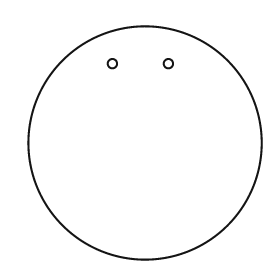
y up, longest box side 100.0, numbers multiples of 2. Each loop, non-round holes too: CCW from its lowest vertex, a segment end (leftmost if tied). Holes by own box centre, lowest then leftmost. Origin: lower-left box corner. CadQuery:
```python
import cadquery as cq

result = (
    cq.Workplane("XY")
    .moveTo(50.0, 50.0)
    .circle(50.0)
    .moveTo(36.0, 84.0)
    .circle(2.0)
    .moveTo(60.0, 84.0)
    .circle(2.0)
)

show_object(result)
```